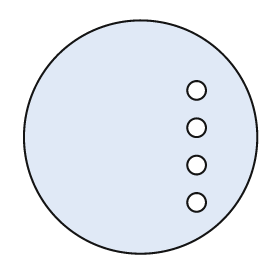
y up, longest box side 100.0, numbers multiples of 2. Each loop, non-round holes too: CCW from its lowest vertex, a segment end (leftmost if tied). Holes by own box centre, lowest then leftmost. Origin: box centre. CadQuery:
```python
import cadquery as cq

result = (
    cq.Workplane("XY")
    .moveTo(0.0, 0.0)
    .circle(50.0)
    .moveTo(24.0, -28.0)
    .circle(4.0)
    .moveTo(24.0, -12.0)
    .circle(4.0)
    .moveTo(24.0, 4.0)
    .circle(4.0)
    .moveTo(24.0, 20.0)
    .circle(4.0)
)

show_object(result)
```